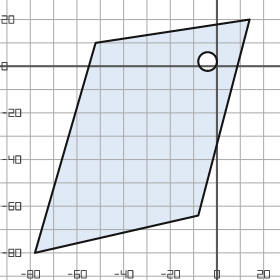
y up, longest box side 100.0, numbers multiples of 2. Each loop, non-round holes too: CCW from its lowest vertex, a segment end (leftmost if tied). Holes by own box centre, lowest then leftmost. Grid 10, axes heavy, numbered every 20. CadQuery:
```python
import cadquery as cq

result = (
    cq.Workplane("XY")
    .moveTo(-78.0, -80.0)
    .lineTo(-8.0, -64.0)
    .lineTo(14.0, 20.0)
    .lineTo(-52.0, 10.0)
    .close()
    .moveTo(-4.0, 2.0)
    .circle(4.0)
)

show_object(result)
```